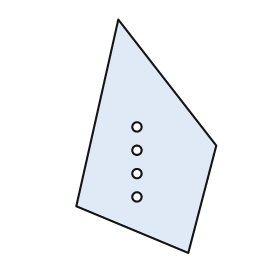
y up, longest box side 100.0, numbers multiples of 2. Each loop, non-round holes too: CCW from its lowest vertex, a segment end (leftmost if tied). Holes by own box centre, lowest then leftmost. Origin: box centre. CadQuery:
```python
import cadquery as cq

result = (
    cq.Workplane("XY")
    .moveTo(18.0, -50.0)
    .lineTo(30.0, -4.0)
    .lineTo(-12.0, 50.0)
    .lineTo(-30.0, -30.0)
    .close()
    .moveTo(-4.0, -26.0)
    .circle(2.0)
    .moveTo(-4.0, -16.0)
    .circle(2.0)
    .moveTo(-4.0, -6.0)
    .circle(2.0)
    .moveTo(-4.0, 4.0)
    .circle(2.0)
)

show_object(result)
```